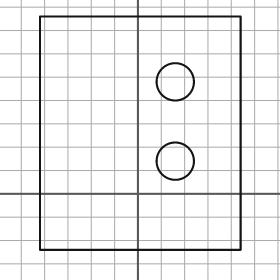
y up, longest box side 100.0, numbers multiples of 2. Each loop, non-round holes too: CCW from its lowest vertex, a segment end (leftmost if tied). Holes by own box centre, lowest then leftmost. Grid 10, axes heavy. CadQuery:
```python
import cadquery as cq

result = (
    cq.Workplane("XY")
    .moveTo(-42.0, -24.0)
    .lineTo(44.0, -24.0)
    .lineTo(44.0, 76.0)
    .lineTo(-42.0, 76.0)
    .close()
    .moveTo(16.0, 14.0)
    .circle(8.0)
    .moveTo(16.0, 48.0)
    .circle(8.0)
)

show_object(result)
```